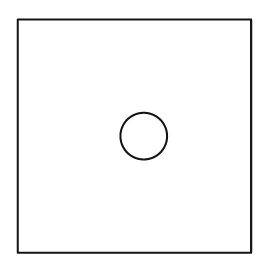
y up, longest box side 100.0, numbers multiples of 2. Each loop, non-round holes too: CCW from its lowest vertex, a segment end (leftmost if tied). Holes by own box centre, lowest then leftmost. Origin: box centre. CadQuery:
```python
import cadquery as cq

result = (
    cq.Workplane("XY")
    .moveTo(-50.0, -50.0)
    .lineTo(50.0, -50.0)
    .lineTo(50.0, 50.0)
    .lineTo(-50.0, 50.0)
    .close()
    .moveTo(4.0, 0.0)
    .circle(10.0)
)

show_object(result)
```